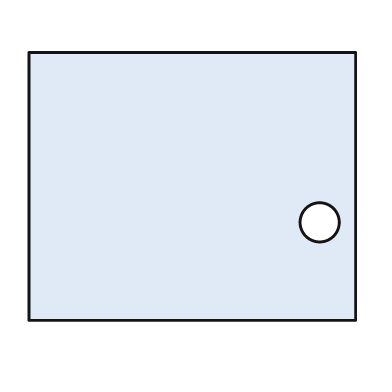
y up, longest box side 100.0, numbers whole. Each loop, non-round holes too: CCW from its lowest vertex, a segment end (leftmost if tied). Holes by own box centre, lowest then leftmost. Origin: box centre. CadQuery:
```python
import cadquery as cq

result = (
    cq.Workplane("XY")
    .moveTo(-50.0, -41.0)
    .lineTo(50.0, -41.0)
    .lineTo(50.0, 41.0)
    .lineTo(-50.0, 41.0)
    .close()
    .moveTo(39.0, -11.0)
    .circle(6.0)
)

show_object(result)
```